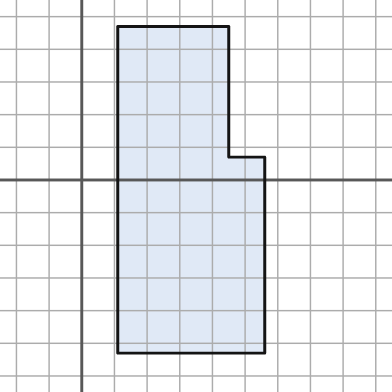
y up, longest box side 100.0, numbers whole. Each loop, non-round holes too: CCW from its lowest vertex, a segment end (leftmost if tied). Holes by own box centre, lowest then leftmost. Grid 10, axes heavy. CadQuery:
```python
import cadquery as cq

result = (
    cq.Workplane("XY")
    .moveTo(11.0, -53.0)
    .lineTo(56.0, -53.0)
    .lineTo(56.0, 7.0)
    .lineTo(45.0, 7.0)
    .lineTo(45.0, 47.0)
    .lineTo(11.0, 47.0)
    .close()
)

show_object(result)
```